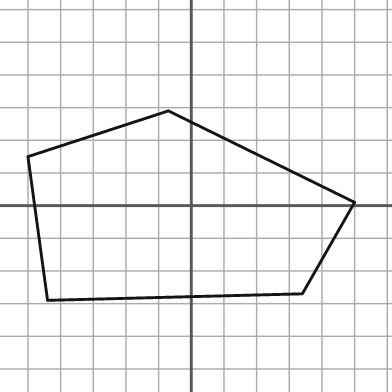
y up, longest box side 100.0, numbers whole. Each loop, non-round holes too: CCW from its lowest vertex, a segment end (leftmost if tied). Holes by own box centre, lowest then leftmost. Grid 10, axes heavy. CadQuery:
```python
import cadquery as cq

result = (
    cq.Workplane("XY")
    .moveTo(-44.0, -29.0)
    .lineTo(34.0, -27.0)
    .lineTo(50.0, 1.0)
    .lineTo(-7.0, 29.0)
    .lineTo(-50.0, 15.0)
    .close()
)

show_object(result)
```